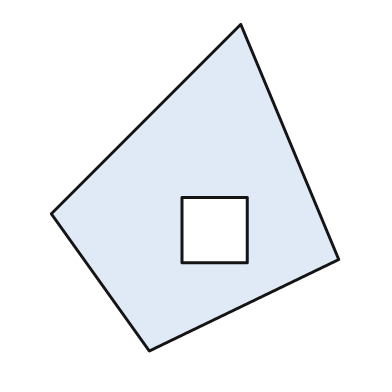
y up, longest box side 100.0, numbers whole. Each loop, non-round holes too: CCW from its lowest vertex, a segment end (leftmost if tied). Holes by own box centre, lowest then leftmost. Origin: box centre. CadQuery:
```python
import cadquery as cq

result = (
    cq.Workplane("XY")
    .moveTo(-14.0, -50.0)
    .lineTo(44.0, -22.0)
    .lineTo(14.0, 50.0)
    .lineTo(-44.0, -8.0)
    .close()
    .moveTo(-4.0, -23.0)
    .lineTo(16.0, -23.0)
    .lineTo(16.0, -3.0)
    .lineTo(-4.0, -3.0)
    .close()
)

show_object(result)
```